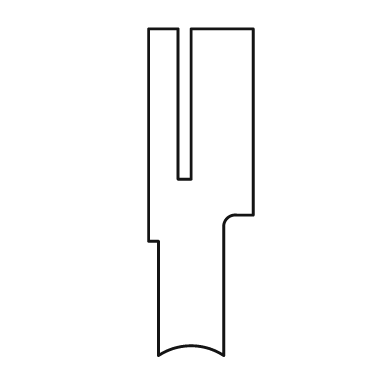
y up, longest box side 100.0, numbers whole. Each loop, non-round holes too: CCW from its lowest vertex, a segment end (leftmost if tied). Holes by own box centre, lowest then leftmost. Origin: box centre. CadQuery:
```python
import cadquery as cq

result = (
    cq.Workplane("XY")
    .moveTo(-13.0, -50.0)
    .threePointArc((-3.0, -47.0), (7.0, -50.0))
    .lineTo(7.0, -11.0)
    .threePointArc((8.0, -8.0), (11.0, -7.0))
    .lineTo(16.0, -7.0)
    .lineTo(16.0, 50.0)
    .lineTo(-3.0, 50.0)
    .lineTo(-3.0, 4.0)
    .lineTo(-7.0, 4.0)
    .lineTo(-7.0, 50.0)
    .lineTo(-16.0, 50.0)
    .lineTo(-16.0, -15.0)
    .lineTo(-13.0, -15.0)
    .close()
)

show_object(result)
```